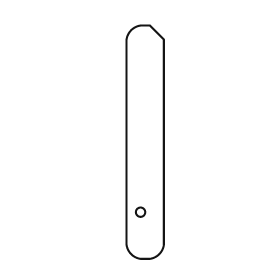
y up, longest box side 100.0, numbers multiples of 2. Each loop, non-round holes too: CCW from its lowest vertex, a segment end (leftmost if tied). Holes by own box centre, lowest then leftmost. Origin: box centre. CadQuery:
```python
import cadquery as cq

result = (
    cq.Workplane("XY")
    .moveTo(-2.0, -50.0)
    .lineTo(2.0, -50.0)
    .threePointArc((6.0, -48.0), (8.0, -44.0))
    .lineTo(8.0, 44.0)
    .lineTo(2.0, 50.0)
    .lineTo(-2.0, 50.0)
    .threePointArc((-6.0, 48.0), (-8.0, 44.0))
    .lineTo(-8.0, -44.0)
    .threePointArc((-6.0, -48.0), (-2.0, -50.0))
    .close()
    .moveTo(-2.0, -30.0)
    .circle(2.0)
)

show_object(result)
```